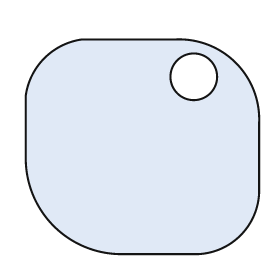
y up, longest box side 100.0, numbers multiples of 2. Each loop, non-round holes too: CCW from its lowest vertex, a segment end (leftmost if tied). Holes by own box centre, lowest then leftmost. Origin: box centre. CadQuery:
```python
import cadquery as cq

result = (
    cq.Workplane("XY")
    .moveTo(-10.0, -46.0)
    .lineTo(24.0, -46.0)
    .threePointArc((42.0, -38.0), (50.0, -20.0))
    .lineTo(50.0, 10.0)
    .threePointArc((40.0, 36.0), (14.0, 46.0))
    .lineTo(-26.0, 46.0)
    .threePointArc((-42.0, 38.0), (-50.0, 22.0))
    .lineTo(-50.0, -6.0)
    .threePointArc((-38.0, -34.0), (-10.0, -46.0))
    .close()
    .moveTo(22.0, 30.0)
    .circle(10.0)
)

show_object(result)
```